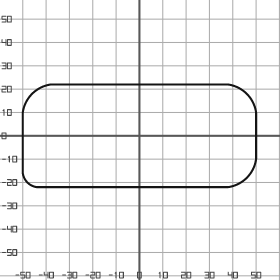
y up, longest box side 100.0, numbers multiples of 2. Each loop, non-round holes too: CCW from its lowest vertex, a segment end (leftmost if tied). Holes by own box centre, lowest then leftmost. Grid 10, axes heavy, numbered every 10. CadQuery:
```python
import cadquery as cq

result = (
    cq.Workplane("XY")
    .moveTo(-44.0, -22.0)
    .lineTo(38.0, -22.0)
    .threePointArc((46.0, -18.0), (50.0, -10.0))
    .lineTo(50.0, 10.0)
    .threePointArc((46.0, 18.0), (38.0, 22.0))
    .lineTo(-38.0, 22.0)
    .threePointArc((-46.0, 18.0), (-50.0, 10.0))
    .lineTo(-50.0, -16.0)
    .threePointArc((-48.0, -20.0), (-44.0, -22.0))
    .close()
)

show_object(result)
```